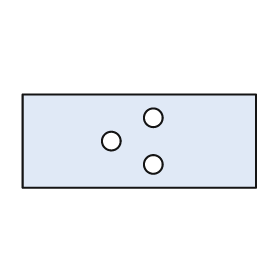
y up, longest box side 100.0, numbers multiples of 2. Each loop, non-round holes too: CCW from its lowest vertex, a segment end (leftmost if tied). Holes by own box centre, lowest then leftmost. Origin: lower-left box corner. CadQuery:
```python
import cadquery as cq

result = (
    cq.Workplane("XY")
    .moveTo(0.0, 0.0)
    .lineTo(100.0, 0.0)
    .lineTo(100.0, 40.0)
    .lineTo(0.0, 40.0)
    .close()
    .moveTo(56.0, 10.0)
    .circle(4.0)
    .moveTo(38.0, 20.0)
    .circle(4.0)
    .moveTo(56.0, 30.0)
    .circle(4.0)
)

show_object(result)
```